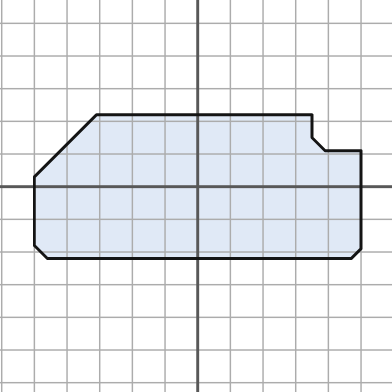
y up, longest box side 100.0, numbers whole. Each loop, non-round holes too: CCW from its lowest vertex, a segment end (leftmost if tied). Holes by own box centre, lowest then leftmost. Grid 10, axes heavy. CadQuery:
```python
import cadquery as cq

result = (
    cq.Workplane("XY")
    .moveTo(-46.0, -22.0)
    .lineTo(47.0, -22.0)
    .lineTo(50.0, -19.0)
    .lineTo(50.0, 11.0)
    .lineTo(39.0, 11.0)
    .lineTo(35.0, 15.0)
    .lineTo(35.0, 22.0)
    .lineTo(-31.0, 22.0)
    .lineTo(-50.0, 3.0)
    .lineTo(-50.0, -18.0)
    .close()
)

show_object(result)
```